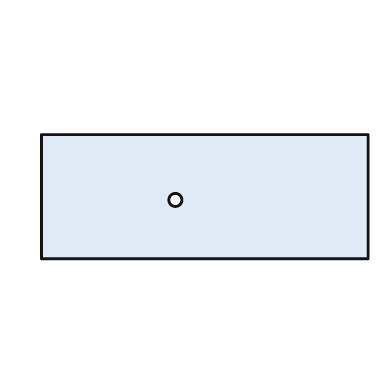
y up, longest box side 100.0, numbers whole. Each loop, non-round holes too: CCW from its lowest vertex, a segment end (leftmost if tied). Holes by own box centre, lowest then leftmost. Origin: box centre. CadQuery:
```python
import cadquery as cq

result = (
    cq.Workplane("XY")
    .moveTo(-50.0, -19.0)
    .lineTo(50.0, -19.0)
    .lineTo(50.0, 19.0)
    .lineTo(-50.0, 19.0)
    .close()
    .moveTo(-9.0, -1.0)
    .circle(2.0)
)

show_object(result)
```